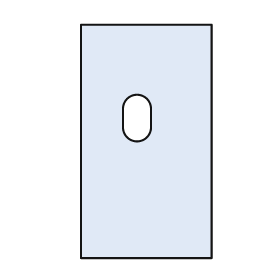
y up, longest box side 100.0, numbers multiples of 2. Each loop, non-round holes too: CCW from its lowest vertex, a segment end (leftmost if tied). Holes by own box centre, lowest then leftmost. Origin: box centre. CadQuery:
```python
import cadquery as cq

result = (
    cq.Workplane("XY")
    .moveTo(-28.0, -50.0)
    .lineTo(28.0, -50.0)
    .lineTo(28.0, 50.0)
    .lineTo(-28.0, 50.0)
    .close()
    .moveTo(-10.0, 6.0)
    .threePointArc((-4.0, 0.0), (2.0, 6.0))
    .lineTo(2.0, 14.0)
    .threePointArc((-4.0, 20.0), (-10.0, 14.0))
    .close()
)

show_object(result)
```